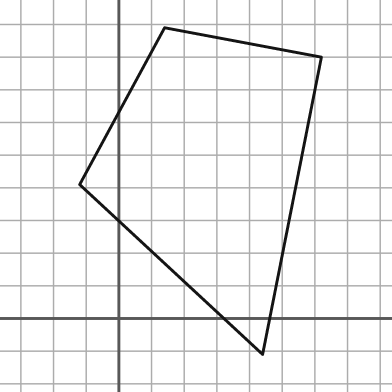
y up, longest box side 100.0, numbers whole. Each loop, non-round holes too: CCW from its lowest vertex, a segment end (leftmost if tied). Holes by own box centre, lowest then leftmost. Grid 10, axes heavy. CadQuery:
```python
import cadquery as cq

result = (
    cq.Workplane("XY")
    .moveTo(44.0, -11.0)
    .lineTo(62.0, 80.0)
    .lineTo(14.0, 89.0)
    .lineTo(-12.0, 41.0)
    .close()
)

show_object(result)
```